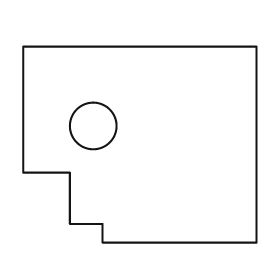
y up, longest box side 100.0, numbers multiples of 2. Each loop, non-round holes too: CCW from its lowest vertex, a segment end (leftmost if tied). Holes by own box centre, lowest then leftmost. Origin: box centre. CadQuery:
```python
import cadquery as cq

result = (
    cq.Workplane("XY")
    .moveTo(-16.0, -42.0)
    .lineTo(50.0, -42.0)
    .lineTo(50.0, 42.0)
    .lineTo(-50.0, 42.0)
    .lineTo(-50.0, -12.0)
    .lineTo(-30.0, -12.0)
    .lineTo(-30.0, -34.0)
    .lineTo(-16.0, -34.0)
    .close()
    .moveTo(-20.0, 8.0)
    .circle(10.0)
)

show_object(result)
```